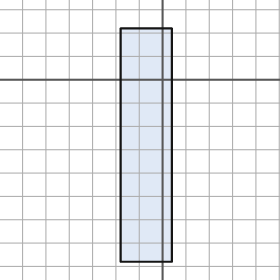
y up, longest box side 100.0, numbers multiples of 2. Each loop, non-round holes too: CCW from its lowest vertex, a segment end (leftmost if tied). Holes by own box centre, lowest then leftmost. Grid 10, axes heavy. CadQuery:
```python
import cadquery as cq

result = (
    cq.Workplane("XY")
    .moveTo(-18.0, -78.0)
    .lineTo(4.0, -78.0)
    .lineTo(4.0, 22.0)
    .lineTo(-18.0, 22.0)
    .close()
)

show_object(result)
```